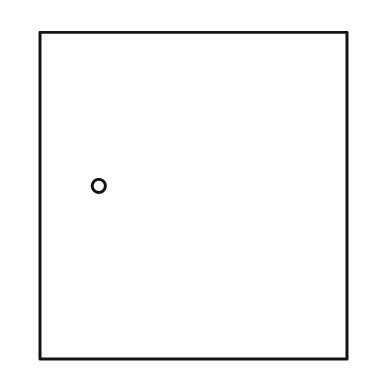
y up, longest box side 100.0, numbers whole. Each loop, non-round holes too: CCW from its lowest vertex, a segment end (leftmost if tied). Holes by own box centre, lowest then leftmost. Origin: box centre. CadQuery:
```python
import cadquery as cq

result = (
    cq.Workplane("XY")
    .moveTo(-47.0, -50.0)
    .lineTo(47.0, -50.0)
    .lineTo(47.0, 50.0)
    .lineTo(-47.0, 50.0)
    .close()
    .moveTo(-29.0, 3.0)
    .circle(2.0)
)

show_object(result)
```